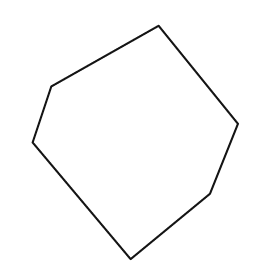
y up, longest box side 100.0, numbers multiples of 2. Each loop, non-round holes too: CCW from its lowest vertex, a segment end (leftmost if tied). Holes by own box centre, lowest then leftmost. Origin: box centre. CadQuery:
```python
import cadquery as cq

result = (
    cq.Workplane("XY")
    .moveTo(-2.0, -50.0)
    .lineTo(32.0, -22.0)
    .lineTo(44.0, 8.0)
    .lineTo(10.0, 50.0)
    .lineTo(-36.0, 24.0)
    .lineTo(-44.0, 0.0)
    .close()
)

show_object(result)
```